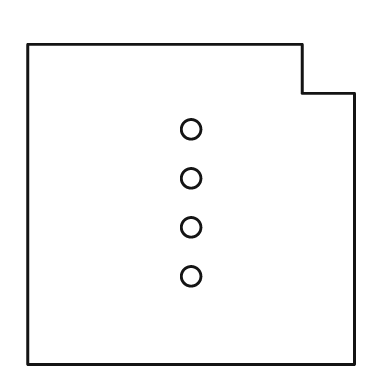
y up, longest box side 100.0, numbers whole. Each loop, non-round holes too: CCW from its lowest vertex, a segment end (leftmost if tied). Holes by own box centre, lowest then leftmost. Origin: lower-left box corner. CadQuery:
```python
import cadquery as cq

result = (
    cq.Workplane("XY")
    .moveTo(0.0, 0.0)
    .lineTo(100.0, 0.0)
    .lineTo(100.0, 83.0)
    .lineTo(84.0, 83.0)
    .lineTo(84.0, 98.0)
    .lineTo(0.0, 98.0)
    .close()
    .moveTo(50.0, 27.0)
    .circle(3.0)
    .moveTo(50.0, 42.0)
    .circle(3.0)
    .moveTo(50.0, 57.0)
    .circle(3.0)
    .moveTo(50.0, 72.0)
    .circle(3.0)
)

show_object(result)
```